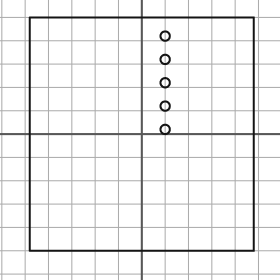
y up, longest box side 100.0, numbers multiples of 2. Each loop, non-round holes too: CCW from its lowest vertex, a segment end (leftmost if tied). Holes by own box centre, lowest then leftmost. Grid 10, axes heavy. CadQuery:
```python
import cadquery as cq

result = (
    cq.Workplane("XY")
    .moveTo(-48.0, -50.0)
    .lineTo(48.0, -50.0)
    .lineTo(48.0, 50.0)
    .lineTo(-48.0, 50.0)
    .close()
    .moveTo(10.0, 2.0)
    .circle(2.0)
    .moveTo(10.0, 12.0)
    .circle(2.0)
    .moveTo(10.0, 22.0)
    .circle(2.0)
    .moveTo(10.0, 32.0)
    .circle(2.0)
    .moveTo(10.0, 42.0)
    .circle(2.0)
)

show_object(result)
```